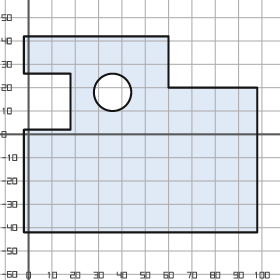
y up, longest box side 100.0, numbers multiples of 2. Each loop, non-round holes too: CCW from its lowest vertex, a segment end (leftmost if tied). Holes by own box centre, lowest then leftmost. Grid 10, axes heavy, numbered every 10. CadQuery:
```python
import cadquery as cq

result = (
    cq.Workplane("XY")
    .moveTo(-2.0, -42.0)
    .lineTo(98.0, -42.0)
    .lineTo(98.0, 20.0)
    .lineTo(60.0, 20.0)
    .lineTo(60.0, 42.0)
    .lineTo(-2.0, 42.0)
    .lineTo(-2.0, 26.0)
    .lineTo(18.0, 26.0)
    .lineTo(18.0, 2.0)
    .lineTo(-2.0, 2.0)
    .close()
    .moveTo(36.0, 18.0)
    .circle(8.0)
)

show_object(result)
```